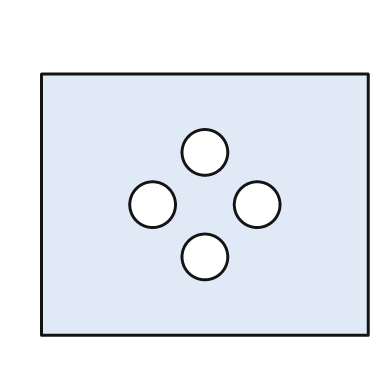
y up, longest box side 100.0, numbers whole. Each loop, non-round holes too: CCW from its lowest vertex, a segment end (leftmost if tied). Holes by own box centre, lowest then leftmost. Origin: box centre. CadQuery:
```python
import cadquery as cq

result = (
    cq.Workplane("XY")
    .moveTo(-50.0, -40.0)
    .lineTo(50.0, -40.0)
    .lineTo(50.0, 40.0)
    .lineTo(-50.0, 40.0)
    .close()
    .moveTo(0.0, -16.0)
    .circle(7.0)
    .moveTo(-16.0, 0.0)
    .circle(7.0)
    .moveTo(16.0, 0.0)
    .circle(7.0)
    .moveTo(0.0, 16.0)
    .circle(7.0)
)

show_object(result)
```